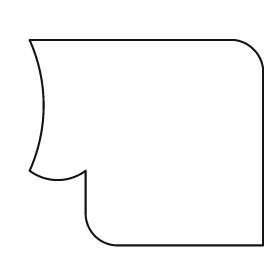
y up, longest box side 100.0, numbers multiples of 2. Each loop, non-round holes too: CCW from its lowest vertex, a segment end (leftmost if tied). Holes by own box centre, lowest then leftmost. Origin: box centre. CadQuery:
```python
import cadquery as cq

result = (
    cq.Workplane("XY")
    .moveTo(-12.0, -44.0)
    .lineTo(50.0, -44.0)
    .lineTo(50.0, 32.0)
    .threePointArc((46.0, 40.0), (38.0, 44.0))
    .lineTo(-50.0, 44.0)
    .threePointArc((-44.0, 16.0), (-50.0, -12.0))
    .threePointArc((-38.0, -16.0), (-26.0, -12.0))
    .lineTo(-26.0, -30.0)
    .threePointArc((-22.0, -40.0), (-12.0, -44.0))
    .close()
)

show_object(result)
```